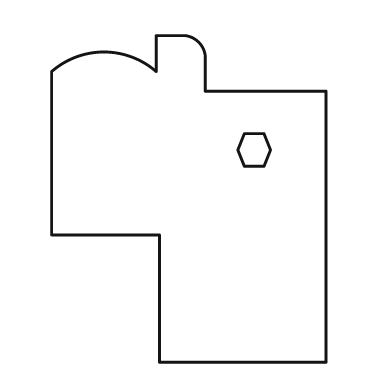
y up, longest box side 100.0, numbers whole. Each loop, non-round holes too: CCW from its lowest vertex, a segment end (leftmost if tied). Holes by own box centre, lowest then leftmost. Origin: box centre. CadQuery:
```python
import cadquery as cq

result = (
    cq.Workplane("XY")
    .moveTo(-9.0, -50.0)
    .lineTo(42.0, -50.0)
    .lineTo(42.0, 33.0)
    .lineTo(5.0, 33.0)
    .lineTo(5.0, 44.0)
    .threePointArc((3.0, 48.0), (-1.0, 50.0))
    .lineTo(-10.0, 50.0)
    .lineTo(-10.0, 39.0)
    .threePointArc((-26.0, 45.0), (-42.0, 39.0))
    .lineTo(-42.0, -11.0)
    .lineTo(-9.0, -11.0)
    .close()
    .moveTo(17.0, 10.0)
    .lineTo(23.0, 10.0)
    .lineTo(25.0, 15.0)
    .lineTo(23.0, 20.0)
    .lineTo(17.0, 20.0)
    .lineTo(15.0, 15.0)
    .close()
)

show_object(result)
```